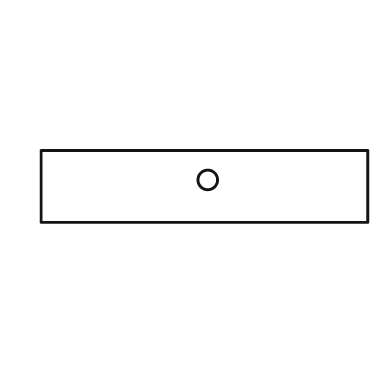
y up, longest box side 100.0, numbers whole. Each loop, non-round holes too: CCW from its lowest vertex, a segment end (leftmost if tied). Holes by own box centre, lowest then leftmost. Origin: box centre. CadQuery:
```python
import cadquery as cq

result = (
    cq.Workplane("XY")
    .moveTo(-50.0, -11.0)
    .lineTo(50.0, -11.0)
    .lineTo(50.0, 11.0)
    .lineTo(-50.0, 11.0)
    .close()
    .moveTo(1.0, 2.0)
    .circle(3.0)
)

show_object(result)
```